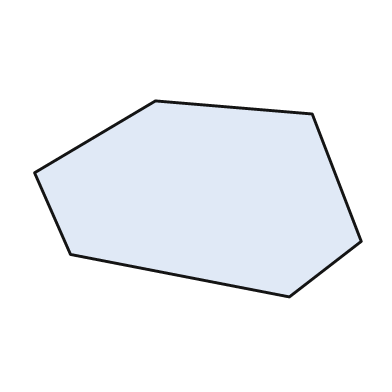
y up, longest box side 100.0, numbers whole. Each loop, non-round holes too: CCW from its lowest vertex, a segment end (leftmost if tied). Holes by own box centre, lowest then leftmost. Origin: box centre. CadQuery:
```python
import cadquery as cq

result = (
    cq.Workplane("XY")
    .moveTo(28.0, -30.0)
    .lineTo(50.0, -13.0)
    .lineTo(35.0, 26.0)
    .lineTo(-13.0, 30.0)
    .lineTo(-50.0, 8.0)
    .lineTo(-39.0, -17.0)
    .close()
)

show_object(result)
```